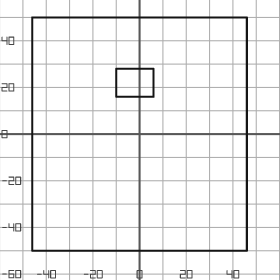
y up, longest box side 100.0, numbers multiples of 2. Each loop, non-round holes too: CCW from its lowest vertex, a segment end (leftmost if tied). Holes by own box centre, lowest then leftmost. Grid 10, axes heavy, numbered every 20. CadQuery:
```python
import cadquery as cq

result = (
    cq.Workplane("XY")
    .moveTo(-46.0, -50.0)
    .lineTo(46.0, -50.0)
    .lineTo(46.0, 50.0)
    .lineTo(-46.0, 50.0)
    .close()
    .moveTo(-10.0, 16.0)
    .lineTo(6.0, 16.0)
    .lineTo(6.0, 28.0)
    .lineTo(-10.0, 28.0)
    .close()
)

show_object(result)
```